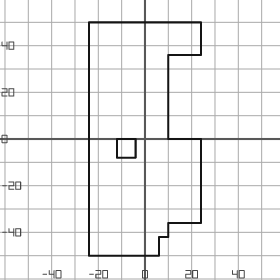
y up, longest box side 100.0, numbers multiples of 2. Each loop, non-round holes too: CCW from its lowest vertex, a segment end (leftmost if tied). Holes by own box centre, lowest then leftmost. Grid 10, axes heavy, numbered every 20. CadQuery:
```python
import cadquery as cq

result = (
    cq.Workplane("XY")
    .moveTo(-24.0, -50.0)
    .lineTo(6.0, -50.0)
    .lineTo(6.0, -42.0)
    .lineTo(10.0, -42.0)
    .lineTo(10.0, -36.0)
    .lineTo(24.0, -36.0)
    .lineTo(24.0, 0.0)
    .lineTo(10.0, 0.0)
    .lineTo(10.0, 36.0)
    .lineTo(24.0, 36.0)
    .lineTo(24.0, 50.0)
    .lineTo(-24.0, 50.0)
    .close()
    .moveTo(-12.0, -8.0)
    .lineTo(-4.0, -8.0)
    .lineTo(-4.0, 0.0)
    .lineTo(-12.0, 0.0)
    .close()
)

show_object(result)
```